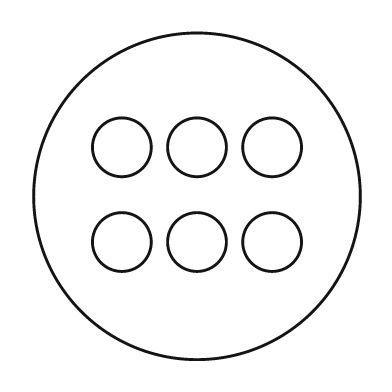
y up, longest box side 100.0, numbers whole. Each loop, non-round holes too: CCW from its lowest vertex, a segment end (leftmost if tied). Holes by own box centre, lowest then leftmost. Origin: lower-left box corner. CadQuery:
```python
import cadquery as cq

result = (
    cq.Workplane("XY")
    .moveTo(50.0, 50.0)
    .circle(50.0)
    .moveTo(27.0, 36.0)
    .circle(9.0)
    .moveTo(50.0, 36.0)
    .circle(9.0)
    .moveTo(73.0, 36.0)
    .circle(9.0)
    .moveTo(27.0, 65.0)
    .circle(9.0)
    .moveTo(50.0, 65.0)
    .circle(9.0)
    .moveTo(73.0, 65.0)
    .circle(9.0)
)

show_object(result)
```